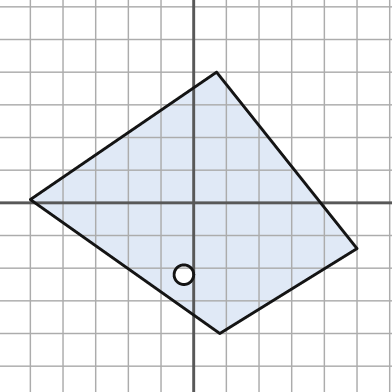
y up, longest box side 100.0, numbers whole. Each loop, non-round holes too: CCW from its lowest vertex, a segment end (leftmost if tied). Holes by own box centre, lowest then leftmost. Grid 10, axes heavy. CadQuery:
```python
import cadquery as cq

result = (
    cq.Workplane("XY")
    .moveTo(8.0, -40.0)
    .lineTo(50.0, -14.0)
    .lineTo(7.0, 40.0)
    .lineTo(-50.0, 1.0)
    .close()
    .moveTo(-3.0, -22.0)
    .circle(3.0)
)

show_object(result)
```